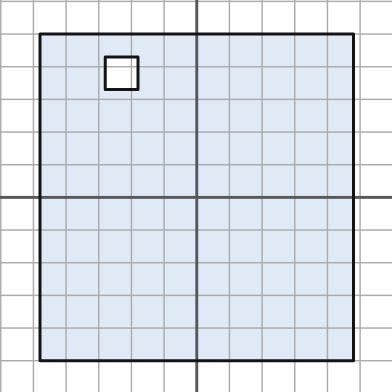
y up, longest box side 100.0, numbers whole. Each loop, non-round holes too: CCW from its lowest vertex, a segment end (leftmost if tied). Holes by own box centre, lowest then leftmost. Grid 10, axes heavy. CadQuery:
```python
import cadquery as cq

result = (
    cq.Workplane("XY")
    .moveTo(-48.0, -50.0)
    .lineTo(48.0, -50.0)
    .lineTo(48.0, 50.0)
    .lineTo(-48.0, 50.0)
    .close()
    .moveTo(-28.0, 33.0)
    .lineTo(-18.0, 33.0)
    .lineTo(-18.0, 43.0)
    .lineTo(-28.0, 43.0)
    .close()
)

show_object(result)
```